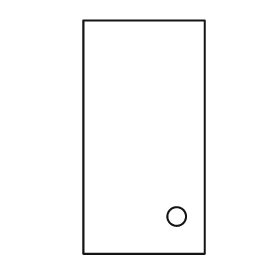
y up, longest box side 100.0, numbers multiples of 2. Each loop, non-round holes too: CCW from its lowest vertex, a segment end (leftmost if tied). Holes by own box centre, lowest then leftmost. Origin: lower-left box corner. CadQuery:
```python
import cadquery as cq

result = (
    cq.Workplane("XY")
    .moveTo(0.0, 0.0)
    .lineTo(52.0, 0.0)
    .lineTo(52.0, 100.0)
    .lineTo(0.0, 100.0)
    .close()
    .moveTo(40.0, 16.0)
    .circle(4.0)
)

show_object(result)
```